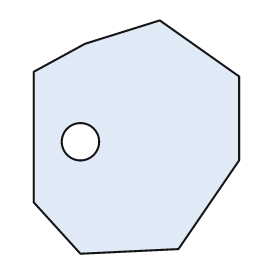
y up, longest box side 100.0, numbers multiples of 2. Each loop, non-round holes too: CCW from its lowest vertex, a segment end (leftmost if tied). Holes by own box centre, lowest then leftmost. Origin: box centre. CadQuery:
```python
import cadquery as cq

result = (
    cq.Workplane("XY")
    .moveTo(-24.0, -50.0)
    .lineTo(18.0, -48.0)
    .lineTo(44.0, -10.0)
    .lineTo(44.0, 26.0)
    .lineTo(10.0, 50.0)
    .lineTo(-22.0, 40.0)
    .lineTo(-44.0, 28.0)
    .lineTo(-44.0, -28.0)
    .close()
    .moveTo(-24.0, -2.0)
    .circle(8.0)
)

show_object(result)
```